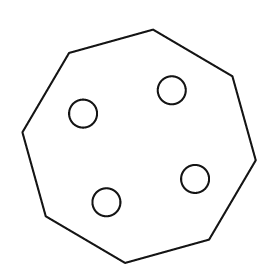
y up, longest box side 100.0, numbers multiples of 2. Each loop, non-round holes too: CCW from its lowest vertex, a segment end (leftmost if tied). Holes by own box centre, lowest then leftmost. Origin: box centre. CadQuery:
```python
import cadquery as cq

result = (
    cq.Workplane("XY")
    .moveTo(-6.0, -50.0)
    .lineTo(30.0, -40.0)
    .lineTo(50.0, -6.0)
    .lineTo(40.0, 30.0)
    .lineTo(6.0, 50.0)
    .lineTo(-30.0, 40.0)
    .lineTo(-50.0, 6.0)
    .lineTo(-40.0, -30.0)
    .close()
    .moveTo(-14.0, -24.0)
    .circle(6.0)
    .moveTo(24.0, -14.0)
    .circle(6.0)
    .moveTo(-24.0, 14.0)
    .circle(6.0)
    .moveTo(14.0, 24.0)
    .circle(6.0)
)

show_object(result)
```